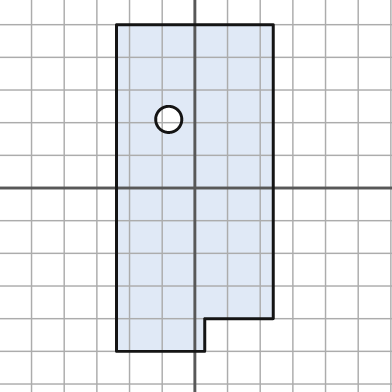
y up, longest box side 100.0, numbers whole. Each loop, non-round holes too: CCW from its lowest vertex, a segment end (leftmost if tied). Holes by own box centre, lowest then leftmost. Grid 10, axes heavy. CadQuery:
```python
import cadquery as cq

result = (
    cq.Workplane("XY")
    .moveTo(-24.0, -50.0)
    .lineTo(3.0, -50.0)
    .lineTo(3.0, -40.0)
    .lineTo(24.0, -40.0)
    .lineTo(24.0, 50.0)
    .lineTo(-24.0, 50.0)
    .close()
    .moveTo(-8.0, 21.0)
    .circle(4.0)
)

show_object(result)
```